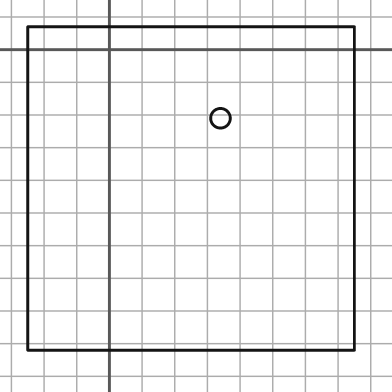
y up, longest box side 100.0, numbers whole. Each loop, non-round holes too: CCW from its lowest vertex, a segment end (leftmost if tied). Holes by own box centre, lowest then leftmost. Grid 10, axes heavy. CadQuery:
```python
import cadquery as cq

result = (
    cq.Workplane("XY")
    .moveTo(-25.0, -92.0)
    .lineTo(75.0, -92.0)
    .lineTo(75.0, 7.0)
    .lineTo(-25.0, 7.0)
    .close()
    .moveTo(34.0, -21.0)
    .circle(3.0)
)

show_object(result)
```